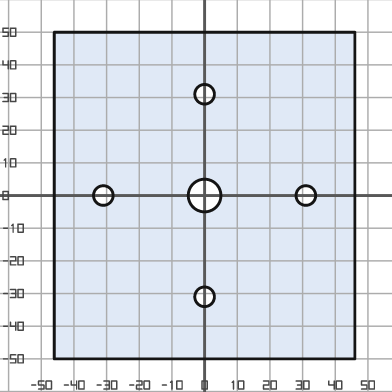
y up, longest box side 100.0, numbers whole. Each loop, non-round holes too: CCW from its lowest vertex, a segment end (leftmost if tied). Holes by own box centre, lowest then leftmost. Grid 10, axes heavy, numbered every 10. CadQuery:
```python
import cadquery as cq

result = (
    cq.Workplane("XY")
    .moveTo(-46.0, -50.0)
    .lineTo(46.0, -50.0)
    .lineTo(46.0, 50.0)
    .lineTo(-46.0, 50.0)
    .close()
    .moveTo(0.0, -31.0)
    .circle(3.0)
    .moveTo(-31.0, 0.0)
    .circle(3.0)
    .moveTo(0.0, 0.0)
    .circle(5.0)
    .moveTo(31.0, 0.0)
    .circle(3.0)
    .moveTo(0.0, 31.0)
    .circle(3.0)
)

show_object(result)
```